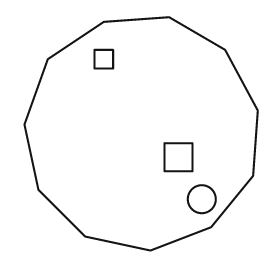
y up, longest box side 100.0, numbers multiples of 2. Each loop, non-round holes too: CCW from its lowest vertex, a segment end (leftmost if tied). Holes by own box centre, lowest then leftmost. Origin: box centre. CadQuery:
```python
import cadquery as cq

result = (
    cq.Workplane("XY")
    .moveTo(4.0, -50.0)
    .lineTo(30.0, -40.0)
    .lineTo(48.0, -18.0)
    .lineTo(50.0, 10.0)
    .lineTo(36.0, 36.0)
    .lineTo(12.0, 50.0)
    .lineTo(-16.0, 48.0)
    .lineTo(-40.0, 32.0)
    .lineTo(-50.0, 4.0)
    .lineTo(-44.0, -24.0)
    .lineTo(-24.0, -44.0)
    .close()
    .moveTo(26.0, -28.0)
    .circle(6.0)
    .moveTo(10.0, -16.0)
    .lineTo(22.0, -16.0)
    .lineTo(22.0, -4.0)
    .lineTo(10.0, -4.0)
    .close()
    .moveTo(-20.0, 28.0)
    .lineTo(-12.0, 28.0)
    .lineTo(-12.0, 36.0)
    .lineTo(-20.0, 36.0)
    .close()
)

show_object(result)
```